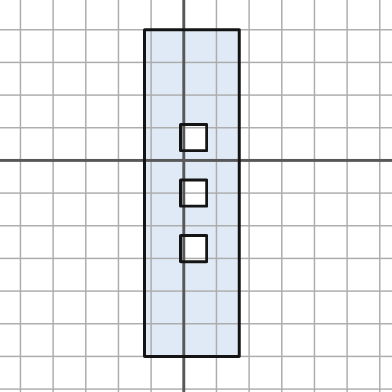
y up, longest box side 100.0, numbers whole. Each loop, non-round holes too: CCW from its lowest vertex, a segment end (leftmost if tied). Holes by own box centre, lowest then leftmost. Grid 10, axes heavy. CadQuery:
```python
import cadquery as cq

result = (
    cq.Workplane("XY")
    .moveTo(-12.0, -60.0)
    .lineTo(17.0, -60.0)
    .lineTo(17.0, 40.0)
    .lineTo(-12.0, 40.0)
    .close()
    .moveTo(-1.0, -31.0)
    .lineTo(7.0, -31.0)
    .lineTo(7.0, -23.0)
    .lineTo(-1.0, -23.0)
    .close()
    .moveTo(-1.0, -14.0)
    .lineTo(7.0, -14.0)
    .lineTo(7.0, -6.0)
    .lineTo(-1.0, -6.0)
    .close()
    .moveTo(-1.0, 3.0)
    .lineTo(7.0, 3.0)
    .lineTo(7.0, 11.0)
    .lineTo(-1.0, 11.0)
    .close()
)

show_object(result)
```